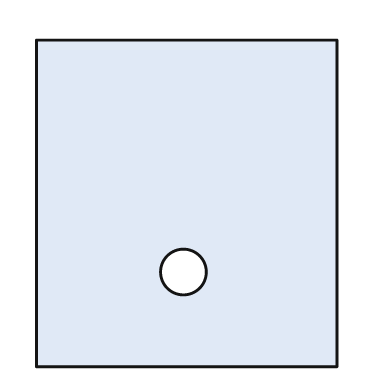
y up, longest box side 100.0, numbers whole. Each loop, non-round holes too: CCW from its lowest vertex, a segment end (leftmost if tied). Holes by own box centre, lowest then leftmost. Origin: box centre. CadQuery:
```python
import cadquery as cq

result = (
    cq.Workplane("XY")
    .moveTo(-46.0, -50.0)
    .lineTo(46.0, -50.0)
    .lineTo(46.0, 50.0)
    .lineTo(-46.0, 50.0)
    .close()
    .moveTo(-1.0, -21.0)
    .circle(7.0)
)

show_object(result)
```